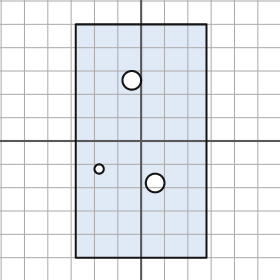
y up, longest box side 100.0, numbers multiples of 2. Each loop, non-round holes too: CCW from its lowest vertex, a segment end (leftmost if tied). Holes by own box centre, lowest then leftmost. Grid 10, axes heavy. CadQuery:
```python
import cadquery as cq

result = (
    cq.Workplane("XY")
    .moveTo(-28.0, -50.0)
    .lineTo(28.0, -50.0)
    .lineTo(28.0, 50.0)
    .lineTo(-28.0, 50.0)
    .close()
    .moveTo(6.0, -18.0)
    .circle(4.0)
    .moveTo(-18.0, -12.0)
    .circle(2.0)
    .moveTo(-4.0, 26.0)
    .circle(4.0)
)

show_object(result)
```